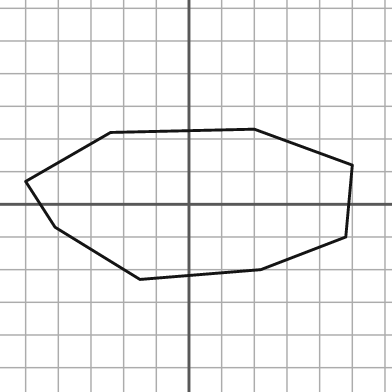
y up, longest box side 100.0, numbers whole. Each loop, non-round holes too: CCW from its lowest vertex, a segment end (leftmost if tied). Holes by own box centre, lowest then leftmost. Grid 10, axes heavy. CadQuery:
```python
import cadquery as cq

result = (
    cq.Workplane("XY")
    .moveTo(-15.0, -23.0)
    .lineTo(22.0, -20.0)
    .lineTo(48.0, -10.0)
    .lineTo(50.0, 12.0)
    .lineTo(20.0, 23.0)
    .lineTo(-24.0, 22.0)
    .lineTo(-50.0, 7.0)
    .lineTo(-41.0, -7.0)
    .close()
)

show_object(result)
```